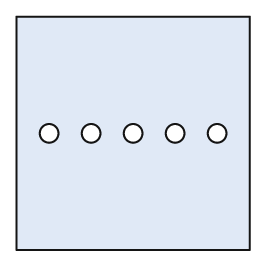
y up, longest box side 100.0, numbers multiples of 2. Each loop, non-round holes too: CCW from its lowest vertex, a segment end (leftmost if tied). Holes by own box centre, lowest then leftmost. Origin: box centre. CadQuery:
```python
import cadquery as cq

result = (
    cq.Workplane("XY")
    .moveTo(-50.0, -50.0)
    .lineTo(50.0, -50.0)
    .lineTo(50.0, 50.0)
    .lineTo(-50.0, 50.0)
    .close()
    .moveTo(-36.0, 0.0)
    .circle(4.0)
    .moveTo(-18.0, 0.0)
    .circle(4.0)
    .moveTo(0.0, 0.0)
    .circle(4.0)
    .moveTo(18.0, 0.0)
    .circle(4.0)
    .moveTo(36.0, 0.0)
    .circle(4.0)
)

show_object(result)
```